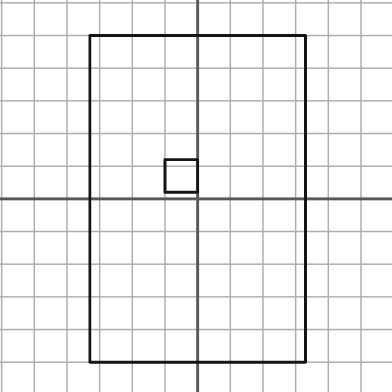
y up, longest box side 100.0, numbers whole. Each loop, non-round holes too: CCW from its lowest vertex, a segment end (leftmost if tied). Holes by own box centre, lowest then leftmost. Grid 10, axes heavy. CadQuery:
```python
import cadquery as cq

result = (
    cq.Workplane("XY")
    .moveTo(-33.0, -50.0)
    .lineTo(33.0, -50.0)
    .lineTo(33.0, 50.0)
    .lineTo(-33.0, 50.0)
    .close()
    .moveTo(-10.0, 2.0)
    .lineTo(0.0, 2.0)
    .lineTo(0.0, 12.0)
    .lineTo(-10.0, 12.0)
    .close()
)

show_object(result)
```